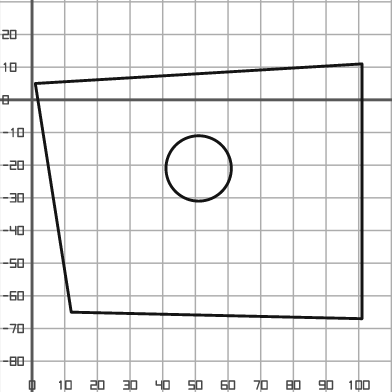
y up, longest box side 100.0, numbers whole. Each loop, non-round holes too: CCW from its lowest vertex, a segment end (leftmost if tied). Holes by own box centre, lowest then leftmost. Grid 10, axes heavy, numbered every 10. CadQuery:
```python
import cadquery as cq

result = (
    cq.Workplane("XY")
    .moveTo(101.0, -67.0)
    .lineTo(101.0, 11.0)
    .lineTo(1.0, 5.0)
    .lineTo(12.0, -65.0)
    .close()
    .moveTo(51.0, -21.0)
    .circle(10.0)
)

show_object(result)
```